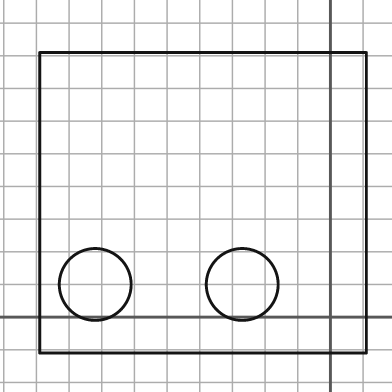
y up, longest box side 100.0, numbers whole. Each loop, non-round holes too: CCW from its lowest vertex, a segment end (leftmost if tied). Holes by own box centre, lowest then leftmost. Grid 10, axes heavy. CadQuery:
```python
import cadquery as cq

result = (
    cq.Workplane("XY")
    .moveTo(-89.0, -11.0)
    .lineTo(11.0, -11.0)
    .lineTo(11.0, 81.0)
    .lineTo(-89.0, 81.0)
    .close()
    .moveTo(-72.0, 10.0)
    .circle(11.0)
    .moveTo(-27.0, 10.0)
    .circle(11.0)
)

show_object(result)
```